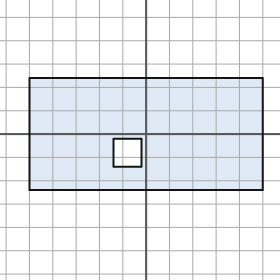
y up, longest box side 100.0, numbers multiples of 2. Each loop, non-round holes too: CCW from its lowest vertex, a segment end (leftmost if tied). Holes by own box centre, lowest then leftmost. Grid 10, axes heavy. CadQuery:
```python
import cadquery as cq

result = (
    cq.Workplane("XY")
    .moveTo(-50.0, -24.0)
    .lineTo(50.0, -24.0)
    .lineTo(50.0, 24.0)
    .lineTo(-50.0, 24.0)
    .close()
    .moveTo(-14.0, -14.0)
    .lineTo(-2.0, -14.0)
    .lineTo(-2.0, -2.0)
    .lineTo(-14.0, -2.0)
    .close()
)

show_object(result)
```